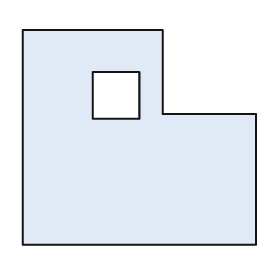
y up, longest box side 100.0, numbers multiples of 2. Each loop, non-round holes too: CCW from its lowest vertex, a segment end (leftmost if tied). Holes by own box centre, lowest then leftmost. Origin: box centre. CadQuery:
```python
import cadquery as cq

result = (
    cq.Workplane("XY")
    .moveTo(-50.0, -46.0)
    .lineTo(50.0, -46.0)
    .lineTo(50.0, 10.0)
    .lineTo(10.0, 10.0)
    .lineTo(10.0, 46.0)
    .lineTo(-50.0, 46.0)
    .close()
    .moveTo(-20.0, 8.0)
    .lineTo(0.0, 8.0)
    .lineTo(0.0, 28.0)
    .lineTo(-20.0, 28.0)
    .close()
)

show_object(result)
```